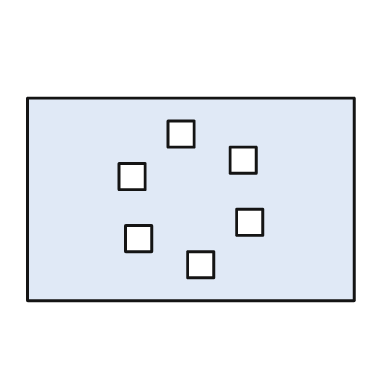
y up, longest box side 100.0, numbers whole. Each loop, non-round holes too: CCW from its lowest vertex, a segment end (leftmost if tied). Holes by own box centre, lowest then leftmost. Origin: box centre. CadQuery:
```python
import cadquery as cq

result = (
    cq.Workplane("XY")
    .moveTo(-50.0, -31.0)
    .lineTo(50.0, -31.0)
    .lineTo(50.0, 31.0)
    .lineTo(-50.0, 31.0)
    .close()
    .moveTo(-1.0, -24.0)
    .lineTo(7.0, -24.0)
    .lineTo(7.0, -16.0)
    .lineTo(-1.0, -16.0)
    .close()
    .moveTo(-20.0, -16.0)
    .lineTo(-12.0, -16.0)
    .lineTo(-12.0, -8.0)
    .lineTo(-20.0, -8.0)
    .close()
    .moveTo(14.0, -11.0)
    .lineTo(22.0, -11.0)
    .lineTo(22.0, -3.0)
    .lineTo(14.0, -3.0)
    .close()
    .moveTo(-22.0, 3.0)
    .lineTo(-14.0, 3.0)
    .lineTo(-14.0, 11.0)
    .lineTo(-22.0, 11.0)
    .close()
    .moveTo(12.0, 8.0)
    .lineTo(20.0, 8.0)
    .lineTo(20.0, 16.0)
    .lineTo(12.0, 16.0)
    .close()
    .moveTo(-7.0, 16.0)
    .lineTo(1.0, 16.0)
    .lineTo(1.0, 24.0)
    .lineTo(-7.0, 24.0)
    .close()
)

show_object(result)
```